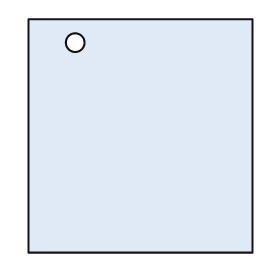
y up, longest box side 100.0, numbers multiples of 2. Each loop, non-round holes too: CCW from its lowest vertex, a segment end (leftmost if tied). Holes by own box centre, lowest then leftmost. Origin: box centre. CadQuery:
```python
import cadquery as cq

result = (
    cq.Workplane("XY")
    .moveTo(-48.0, -50.0)
    .lineTo(48.0, -50.0)
    .lineTo(48.0, 50.0)
    .lineTo(-48.0, 50.0)
    .close()
    .moveTo(-28.0, 40.0)
    .circle(4.0)
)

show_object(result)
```